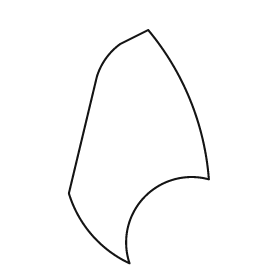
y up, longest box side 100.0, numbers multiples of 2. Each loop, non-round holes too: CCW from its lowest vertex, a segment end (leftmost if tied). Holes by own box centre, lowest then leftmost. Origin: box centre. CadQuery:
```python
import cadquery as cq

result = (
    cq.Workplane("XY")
    .moveTo(-4.0, -50.0)
    .threePointArc((2.0, -22.0), (30.0, -14.0))
    .threePointArc((22.0, 20.0), (4.0, 50.0))
    .lineTo(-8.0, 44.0)
    .threePointArc((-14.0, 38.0), (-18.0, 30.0))
    .lineTo(-30.0, -20.0)
    .threePointArc((-20.0, -38.0), (-4.0, -50.0))
    .close()
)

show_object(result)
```